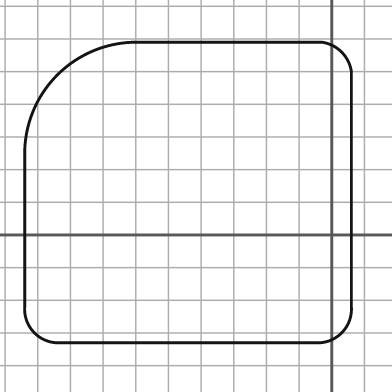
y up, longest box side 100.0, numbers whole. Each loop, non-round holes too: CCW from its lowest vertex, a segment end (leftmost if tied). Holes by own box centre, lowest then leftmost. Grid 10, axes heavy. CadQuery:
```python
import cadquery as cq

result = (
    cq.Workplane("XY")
    .moveTo(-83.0, -33.0)
    .lineTo(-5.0, -33.0)
    .threePointArc((3.0, -30.0), (6.0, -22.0))
    .lineTo(6.0, 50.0)
    .threePointArc((3.0, 56.0), (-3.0, 59.0))
    .lineTo(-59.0, 59.0)
    .threePointArc((-84.0, 49.0), (-94.0, 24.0))
    .lineTo(-94.0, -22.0)
    .threePointArc((-91.0, -30.0), (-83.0, -33.0))
    .close()
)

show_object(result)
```